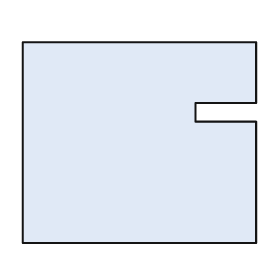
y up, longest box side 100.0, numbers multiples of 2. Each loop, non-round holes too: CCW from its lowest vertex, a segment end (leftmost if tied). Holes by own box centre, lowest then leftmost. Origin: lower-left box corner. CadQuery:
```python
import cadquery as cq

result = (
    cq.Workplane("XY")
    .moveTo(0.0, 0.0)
    .lineTo(100.0, 0.0)
    .lineTo(100.0, 52.0)
    .lineTo(74.0, 52.0)
    .lineTo(74.0, 60.0)
    .lineTo(100.0, 60.0)
    .lineTo(100.0, 86.0)
    .lineTo(0.0, 86.0)
    .close()
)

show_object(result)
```